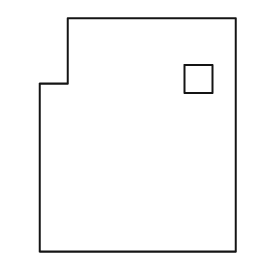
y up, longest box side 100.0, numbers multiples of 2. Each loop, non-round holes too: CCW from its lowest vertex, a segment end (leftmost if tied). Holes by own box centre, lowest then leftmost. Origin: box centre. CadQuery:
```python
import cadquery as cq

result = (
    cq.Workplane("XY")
    .moveTo(-42.0, -50.0)
    .lineTo(42.0, -50.0)
    .lineTo(42.0, 50.0)
    .lineTo(-30.0, 50.0)
    .lineTo(-30.0, 22.0)
    .lineTo(-42.0, 22.0)
    .close()
    .moveTo(20.0, 18.0)
    .lineTo(32.0, 18.0)
    .lineTo(32.0, 30.0)
    .lineTo(20.0, 30.0)
    .close()
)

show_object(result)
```